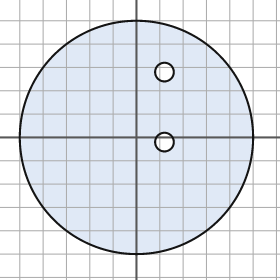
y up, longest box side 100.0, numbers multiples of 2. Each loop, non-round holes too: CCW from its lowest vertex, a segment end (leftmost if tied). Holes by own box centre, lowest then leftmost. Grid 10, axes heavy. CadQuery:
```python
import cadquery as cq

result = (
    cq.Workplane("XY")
    .moveTo(0.0, 0.0)
    .circle(50.0)
    .moveTo(12.0, -2.0)
    .circle(4.0)
    .moveTo(12.0, 28.0)
    .circle(4.0)
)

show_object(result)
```